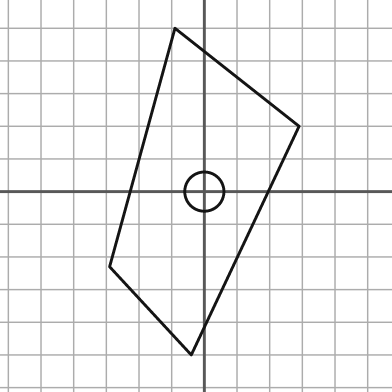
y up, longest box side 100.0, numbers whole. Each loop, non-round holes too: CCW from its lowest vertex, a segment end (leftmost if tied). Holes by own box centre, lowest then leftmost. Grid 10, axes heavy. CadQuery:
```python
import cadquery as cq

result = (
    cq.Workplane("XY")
    .moveTo(-4.0, -50.0)
    .lineTo(29.0, 20.0)
    .lineTo(-9.0, 50.0)
    .lineTo(-29.0, -23.0)
    .close()
    .moveTo(0.0, 0.0)
    .circle(6.0)
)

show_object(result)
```